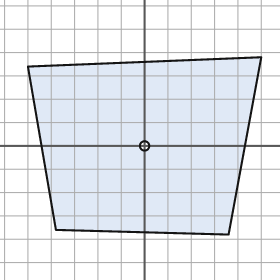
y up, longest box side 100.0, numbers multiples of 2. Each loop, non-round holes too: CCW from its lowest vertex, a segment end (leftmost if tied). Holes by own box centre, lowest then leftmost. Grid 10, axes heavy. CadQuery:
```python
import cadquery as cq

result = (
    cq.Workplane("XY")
    .moveTo(36.0, -38.0)
    .lineTo(50.0, 38.0)
    .lineTo(-50.0, 34.0)
    .lineTo(-38.0, -36.0)
    .close()
    .moveTo(0.0, 0.0)
    .circle(2.0)
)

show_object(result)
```